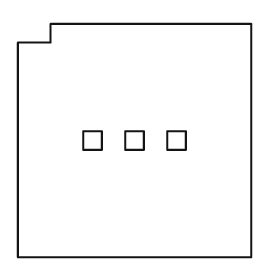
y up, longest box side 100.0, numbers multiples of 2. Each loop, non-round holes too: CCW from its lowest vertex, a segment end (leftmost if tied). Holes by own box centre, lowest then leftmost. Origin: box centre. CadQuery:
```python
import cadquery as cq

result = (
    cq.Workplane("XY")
    .moveTo(-50.0, -50.0)
    .lineTo(50.0, -50.0)
    .lineTo(50.0, 50.0)
    .lineTo(-36.0, 50.0)
    .lineTo(-36.0, 42.0)
    .lineTo(-50.0, 42.0)
    .close()
    .moveTo(-22.0, -4.0)
    .lineTo(-14.0, -4.0)
    .lineTo(-14.0, 4.0)
    .lineTo(-22.0, 4.0)
    .close()
    .moveTo(-4.0, -4.0)
    .lineTo(4.0, -4.0)
    .lineTo(4.0, 4.0)
    .lineTo(-4.0, 4.0)
    .close()
    .moveTo(14.0, -4.0)
    .lineTo(22.0, -4.0)
    .lineTo(22.0, 4.0)
    .lineTo(14.0, 4.0)
    .close()
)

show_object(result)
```